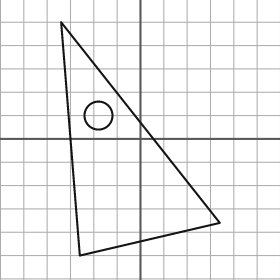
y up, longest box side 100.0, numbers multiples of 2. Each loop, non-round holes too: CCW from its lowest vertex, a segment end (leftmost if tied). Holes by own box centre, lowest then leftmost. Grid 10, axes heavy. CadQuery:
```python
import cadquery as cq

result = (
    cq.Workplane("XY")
    .moveTo(-26.0, -50.0)
    .lineTo(34.0, -36.0)
    .lineTo(-34.0, 50.0)
    .close()
    .moveTo(-18.0, 10.0)
    .circle(6.0)
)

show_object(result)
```